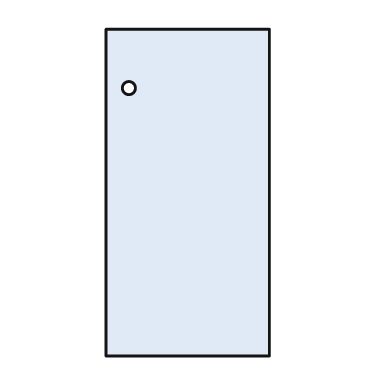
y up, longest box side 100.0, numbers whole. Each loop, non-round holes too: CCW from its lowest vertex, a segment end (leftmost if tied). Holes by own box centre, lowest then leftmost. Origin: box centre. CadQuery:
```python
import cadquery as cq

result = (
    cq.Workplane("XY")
    .moveTo(-25.0, -50.0)
    .lineTo(25.0, -50.0)
    .lineTo(25.0, 50.0)
    .lineTo(-25.0, 50.0)
    .close()
    .moveTo(-18.0, 32.0)
    .circle(2.0)
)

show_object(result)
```